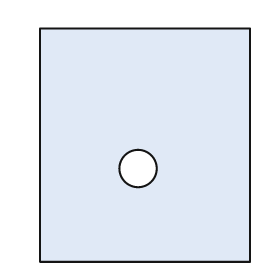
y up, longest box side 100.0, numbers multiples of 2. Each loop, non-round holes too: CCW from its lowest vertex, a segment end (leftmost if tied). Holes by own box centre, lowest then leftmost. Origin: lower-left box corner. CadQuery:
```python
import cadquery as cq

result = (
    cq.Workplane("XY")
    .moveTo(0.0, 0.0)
    .lineTo(90.0, 0.0)
    .lineTo(90.0, 100.0)
    .lineTo(0.0, 100.0)
    .close()
    .moveTo(42.0, 40.0)
    .circle(8.0)
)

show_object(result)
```